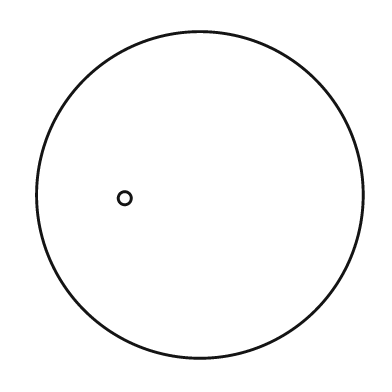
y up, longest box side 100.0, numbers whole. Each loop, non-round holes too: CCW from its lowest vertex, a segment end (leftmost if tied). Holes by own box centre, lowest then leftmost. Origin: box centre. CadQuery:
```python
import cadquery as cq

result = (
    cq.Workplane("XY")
    .moveTo(0.0, 0.0)
    .circle(50.0)
    .moveTo(-23.0, -1.0)
    .circle(2.0)
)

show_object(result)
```